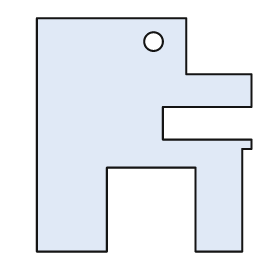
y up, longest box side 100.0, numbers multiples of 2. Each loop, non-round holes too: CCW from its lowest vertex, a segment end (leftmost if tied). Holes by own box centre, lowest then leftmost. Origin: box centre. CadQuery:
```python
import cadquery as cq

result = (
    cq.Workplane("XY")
    .moveTo(-46.0, -50.0)
    .lineTo(-16.0, -50.0)
    .lineTo(-16.0, -14.0)
    .lineTo(22.0, -14.0)
    .lineTo(22.0, -50.0)
    .lineTo(42.0, -50.0)
    .lineTo(42.0, -6.0)
    .lineTo(46.0, -6.0)
    .lineTo(46.0, -2.0)
    .lineTo(8.0, -2.0)
    .lineTo(8.0, 12.0)
    .lineTo(46.0, 12.0)
    .lineTo(46.0, 26.0)
    .lineTo(18.0, 26.0)
    .lineTo(18.0, 50.0)
    .lineTo(-46.0, 50.0)
    .close()
    .moveTo(4.0, 40.0)
    .circle(4.0)
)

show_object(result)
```